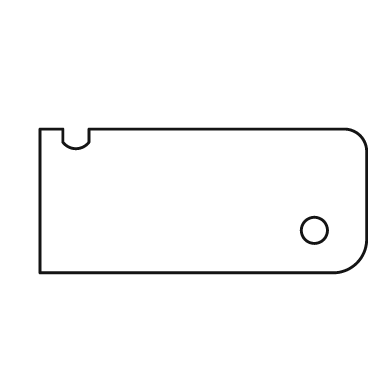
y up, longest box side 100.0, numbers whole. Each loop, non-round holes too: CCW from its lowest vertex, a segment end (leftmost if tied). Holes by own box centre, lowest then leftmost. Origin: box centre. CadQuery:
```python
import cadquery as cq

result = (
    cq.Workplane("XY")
    .moveTo(-50.0, -22.0)
    .lineTo(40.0, -22.0)
    .threePointArc((47.0, -19.0), (50.0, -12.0))
    .lineTo(50.0, 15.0)
    .threePointArc((48.0, 20.0), (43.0, 22.0))
    .lineTo(-35.0, 22.0)
    .lineTo(-35.0, 18.0)
    .threePointArc((-39.0, 16.0), (-43.0, 18.0))
    .lineTo(-43.0, 22.0)
    .lineTo(-50.0, 22.0)
    .close()
    .moveTo(34.0, -9.0)
    .circle(4.0)
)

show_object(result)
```